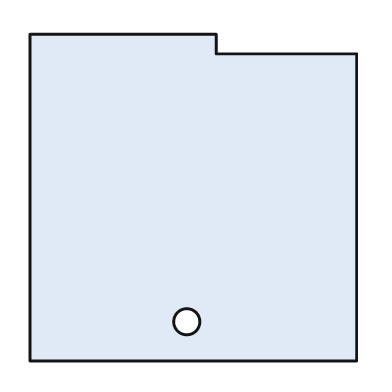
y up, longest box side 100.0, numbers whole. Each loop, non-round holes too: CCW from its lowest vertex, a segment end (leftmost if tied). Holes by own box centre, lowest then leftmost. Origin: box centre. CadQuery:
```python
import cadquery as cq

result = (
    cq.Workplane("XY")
    .moveTo(-50.0, -50.0)
    .lineTo(50.0, -50.0)
    .lineTo(50.0, 44.0)
    .lineTo(7.0, 44.0)
    .lineTo(7.0, 50.0)
    .lineTo(-50.0, 50.0)
    .close()
    .moveTo(-2.0, -38.0)
    .circle(4.0)
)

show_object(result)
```